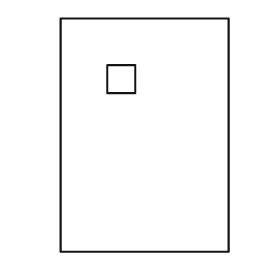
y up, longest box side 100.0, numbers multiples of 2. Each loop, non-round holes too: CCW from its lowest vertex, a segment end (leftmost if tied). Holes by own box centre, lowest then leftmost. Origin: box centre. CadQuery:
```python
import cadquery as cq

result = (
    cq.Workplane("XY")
    .moveTo(-36.0, -50.0)
    .lineTo(36.0, -50.0)
    .lineTo(36.0, 50.0)
    .lineTo(-36.0, 50.0)
    .close()
    .moveTo(-16.0, 18.0)
    .lineTo(-4.0, 18.0)
    .lineTo(-4.0, 30.0)
    .lineTo(-16.0, 30.0)
    .close()
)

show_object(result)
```